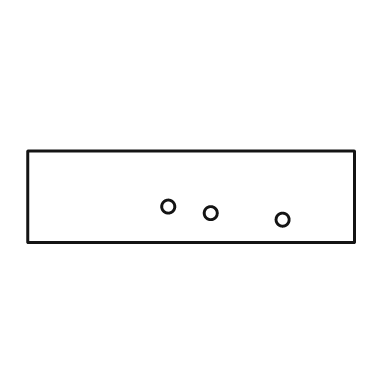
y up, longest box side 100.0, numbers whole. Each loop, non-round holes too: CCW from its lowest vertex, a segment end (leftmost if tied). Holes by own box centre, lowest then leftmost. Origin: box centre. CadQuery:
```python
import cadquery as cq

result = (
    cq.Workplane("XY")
    .moveTo(-50.0, -14.0)
    .lineTo(50.0, -14.0)
    .lineTo(50.0, 14.0)
    .lineTo(-50.0, 14.0)
    .close()
    .moveTo(28.0, -7.0)
    .circle(2.0)
    .moveTo(6.0, -5.0)
    .circle(2.0)
    .moveTo(-7.0, -3.0)
    .circle(2.0)
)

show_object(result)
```